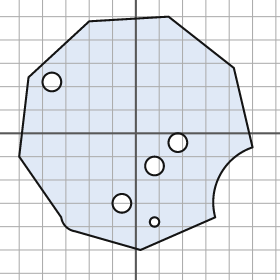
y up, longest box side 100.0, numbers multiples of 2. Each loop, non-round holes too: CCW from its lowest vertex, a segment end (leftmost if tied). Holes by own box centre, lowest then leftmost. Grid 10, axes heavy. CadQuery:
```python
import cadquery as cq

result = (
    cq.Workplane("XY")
    .moveTo(2.0, -50.0)
    .lineTo(34.0, -36.0)
    .threePointArc((36.0, -18.0), (50.0, -6.0))
    .lineTo(42.0, 28.0)
    .lineTo(14.0, 50.0)
    .lineTo(-20.0, 48.0)
    .lineTo(-46.0, 24.0)
    .lineTo(-50.0, -10.0)
    .lineTo(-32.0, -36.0)
    .threePointArc((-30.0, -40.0), (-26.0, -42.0))
    .close()
    .moveTo(8.0, -38.0)
    .circle(2.0)
    .moveTo(-6.0, -30.0)
    .circle(4.0)
    .moveTo(8.0, -14.0)
    .circle(4.0)
    .moveTo(18.0, -4.0)
    .circle(4.0)
    .moveTo(-36.0, 22.0)
    .circle(4.0)
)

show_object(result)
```